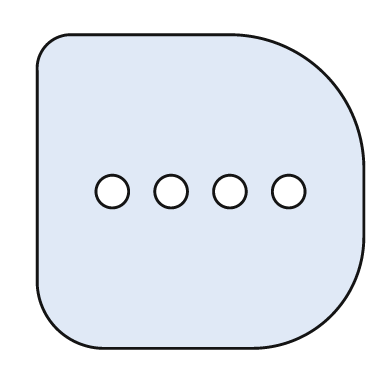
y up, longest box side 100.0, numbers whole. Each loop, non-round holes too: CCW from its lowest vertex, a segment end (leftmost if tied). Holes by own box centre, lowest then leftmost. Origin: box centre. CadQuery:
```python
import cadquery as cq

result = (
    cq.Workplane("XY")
    .moveTo(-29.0, -48.0)
    .lineTo(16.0, -48.0)
    .threePointArc((40.0, -38.0), (50.0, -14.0))
    .lineTo(50.0, 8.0)
    .threePointArc((38.0, 36.0), (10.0, 48.0))
    .lineTo(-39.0, 48.0)
    .threePointArc((-47.0, 45.0), (-50.0, 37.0))
    .lineTo(-50.0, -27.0)
    .threePointArc((-44.0, -42.0), (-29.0, -48.0))
    .close()
    .moveTo(-27.0, 0.0)
    .circle(5.0)
    .moveTo(-9.0, 0.0)
    .circle(5.0)
    .moveTo(9.0, 0.0)
    .circle(5.0)
    .moveTo(27.0, 0.0)
    .circle(5.0)
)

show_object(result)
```